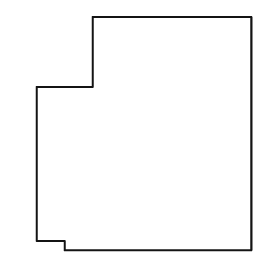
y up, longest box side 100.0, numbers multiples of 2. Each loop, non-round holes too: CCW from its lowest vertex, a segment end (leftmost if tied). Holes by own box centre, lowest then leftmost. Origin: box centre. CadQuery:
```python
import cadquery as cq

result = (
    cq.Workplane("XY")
    .moveTo(-34.0, -50.0)
    .lineTo(46.0, -50.0)
    .lineTo(46.0, 50.0)
    .lineTo(-22.0, 50.0)
    .lineTo(-22.0, 20.0)
    .lineTo(-46.0, 20.0)
    .lineTo(-46.0, -46.0)
    .lineTo(-34.0, -46.0)
    .close()
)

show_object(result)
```